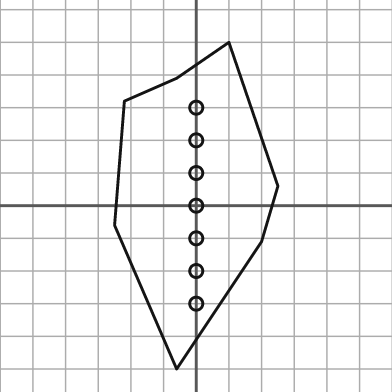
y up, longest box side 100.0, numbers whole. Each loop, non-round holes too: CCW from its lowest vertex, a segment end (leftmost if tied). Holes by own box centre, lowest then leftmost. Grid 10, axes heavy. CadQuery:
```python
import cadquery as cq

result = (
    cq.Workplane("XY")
    .moveTo(-6.0, -50.0)
    .lineTo(20.0, -11.0)
    .lineTo(25.0, 6.0)
    .lineTo(10.0, 50.0)
    .lineTo(-6.0, 39.0)
    .lineTo(-22.0, 32.0)
    .lineTo(-25.0, -6.0)
    .close()
    .moveTo(0.0, -30.0)
    .circle(2.0)
    .moveTo(0.0, -20.0)
    .circle(2.0)
    .moveTo(0.0, -10.0)
    .circle(2.0)
    .moveTo(0.0, 0.0)
    .circle(2.0)
    .moveTo(0.0, 10.0)
    .circle(2.0)
    .moveTo(0.0, 20.0)
    .circle(2.0)
    .moveTo(0.0, 30.0)
    .circle(2.0)
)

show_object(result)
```